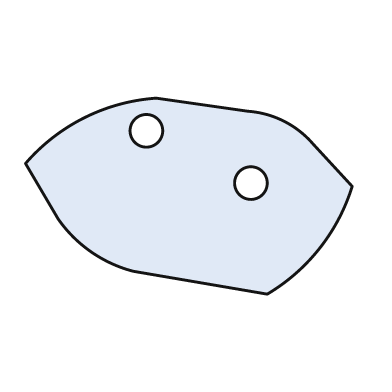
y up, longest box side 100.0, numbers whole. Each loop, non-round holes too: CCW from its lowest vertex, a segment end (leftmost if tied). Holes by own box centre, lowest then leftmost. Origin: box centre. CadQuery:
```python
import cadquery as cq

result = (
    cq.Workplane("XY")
    .moveTo(24.0, -30.0)
    .threePointArc((40.0, -16.0), (50.0, 3.0))
    .lineTo(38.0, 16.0)
    .threePointArc((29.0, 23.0), (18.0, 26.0))
    .lineTo(-10.0, 30.0)
    .threePointArc((-32.0, 24.0), (-50.0, 10.0))
    .lineTo(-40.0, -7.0)
    .threePointArc((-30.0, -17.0), (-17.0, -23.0))
    .close()
    .moveTo(19.0, 4.0)
    .circle(5.0)
    .moveTo(-13.0, 20.0)
    .circle(5.0)
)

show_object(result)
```